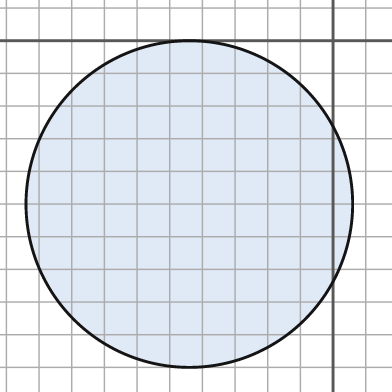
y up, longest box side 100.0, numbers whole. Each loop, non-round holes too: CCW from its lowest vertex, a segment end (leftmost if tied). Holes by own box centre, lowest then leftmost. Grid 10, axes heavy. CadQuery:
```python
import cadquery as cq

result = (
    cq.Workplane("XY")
    .moveTo(-44.0, -50.0)
    .circle(50.0)
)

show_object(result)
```